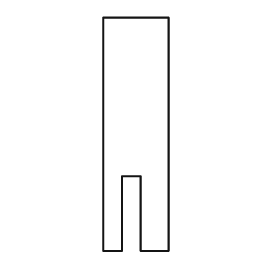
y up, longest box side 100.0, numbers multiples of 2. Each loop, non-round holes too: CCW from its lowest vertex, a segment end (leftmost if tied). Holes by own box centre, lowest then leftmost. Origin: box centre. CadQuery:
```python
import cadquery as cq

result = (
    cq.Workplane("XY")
    .moveTo(-14.0, -50.0)
    .lineTo(-6.0, -50.0)
    .lineTo(-6.0, -18.0)
    .lineTo(2.0, -18.0)
    .lineTo(2.0, -50.0)
    .lineTo(14.0, -50.0)
    .lineTo(14.0, 50.0)
    .lineTo(-14.0, 50.0)
    .close()
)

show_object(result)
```